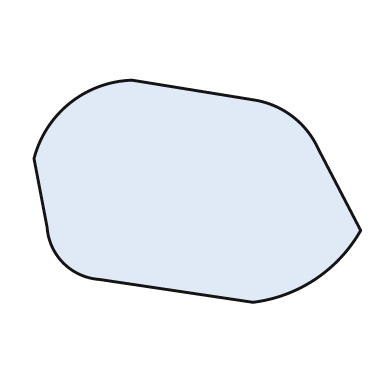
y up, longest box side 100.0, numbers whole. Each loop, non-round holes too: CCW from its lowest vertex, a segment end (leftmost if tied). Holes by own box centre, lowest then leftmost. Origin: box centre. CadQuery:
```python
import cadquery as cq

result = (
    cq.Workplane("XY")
    .moveTo(17.0, -34.0)
    .threePointArc((36.0, -27.0), (50.0, -12.0))
    .lineTo(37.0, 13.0)
    .threePointArc((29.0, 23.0), (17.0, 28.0))
    .lineTo(-20.0, 34.0)
    .threePointArc((-39.0, 27.0), (-50.0, 10.0))
    .lineTo(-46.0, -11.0)
    .threePointArc((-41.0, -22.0), (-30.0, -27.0))
    .close()
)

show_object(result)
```